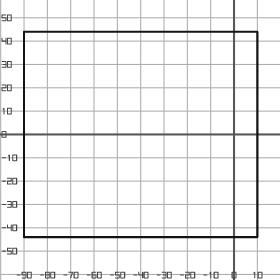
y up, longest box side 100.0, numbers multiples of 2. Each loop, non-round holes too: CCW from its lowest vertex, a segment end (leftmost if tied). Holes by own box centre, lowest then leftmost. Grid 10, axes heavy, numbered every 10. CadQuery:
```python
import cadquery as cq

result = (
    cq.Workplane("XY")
    .moveTo(-90.0, -44.0)
    .lineTo(10.0, -44.0)
    .lineTo(10.0, 44.0)
    .lineTo(-90.0, 44.0)
    .close()
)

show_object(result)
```